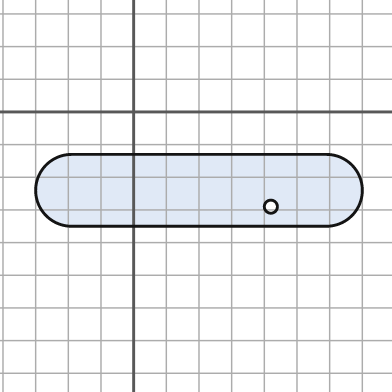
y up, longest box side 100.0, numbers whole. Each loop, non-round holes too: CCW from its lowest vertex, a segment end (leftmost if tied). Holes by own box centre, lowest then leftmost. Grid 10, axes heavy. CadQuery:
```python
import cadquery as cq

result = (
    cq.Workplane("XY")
    .moveTo(-19.0, -35.0)
    .lineTo(59.0, -35.0)
    .threePointArc((70.0, -24.0), (59.0, -13.0))
    .lineTo(-19.0, -13.0)
    .threePointArc((-30.0, -24.0), (-19.0, -35.0))
    .close()
    .moveTo(42.0, -29.0)
    .circle(2.0)
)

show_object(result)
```